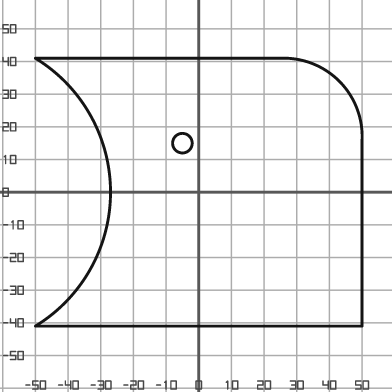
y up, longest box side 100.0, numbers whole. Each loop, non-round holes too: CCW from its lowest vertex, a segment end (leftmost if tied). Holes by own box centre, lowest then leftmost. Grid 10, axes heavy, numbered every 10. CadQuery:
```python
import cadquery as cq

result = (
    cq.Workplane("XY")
    .moveTo(-50.0, -41.0)
    .lineTo(50.0, -41.0)
    .lineTo(50.0, 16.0)
    .threePointArc((43.0, 34.0), (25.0, 41.0))
    .lineTo(-50.0, 41.0)
    .threePointArc((-27.0, 0.0), (-50.0, -41.0))
    .close()
    .moveTo(-5.0, 15.0)
    .circle(3.0)
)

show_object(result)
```